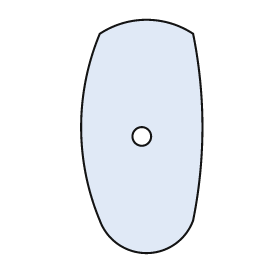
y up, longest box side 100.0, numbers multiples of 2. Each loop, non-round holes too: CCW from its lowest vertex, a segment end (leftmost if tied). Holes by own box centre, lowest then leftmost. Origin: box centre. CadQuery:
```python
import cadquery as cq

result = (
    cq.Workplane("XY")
    .moveTo(-18.0, -36.0)
    .threePointArc((2.0, -50.0), (22.0, -36.0))
    .threePointArc((26.0, 4.0), (22.0, 44.0))
    .threePointArc((2.0, 50.0), (-18.0, 44.0))
    .threePointArc((-26.0, 4.0), (-18.0, -36.0))
    .close()
    .moveTo(0.0, 0.0)
    .circle(4.0)
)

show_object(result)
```